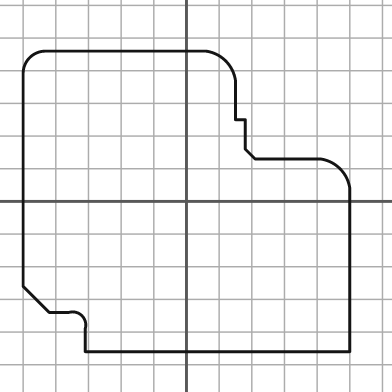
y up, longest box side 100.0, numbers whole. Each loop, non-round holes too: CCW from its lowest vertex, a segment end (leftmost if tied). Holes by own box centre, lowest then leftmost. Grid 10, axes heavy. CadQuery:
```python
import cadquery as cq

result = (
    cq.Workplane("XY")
    .moveTo(-31.0, -46.0)
    .lineTo(50.0, -46.0)
    .lineTo(50.0, 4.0)
    .threePointArc((47.0, 10.0), (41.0, 13.0))
    .lineTo(21.0, 13.0)
    .lineTo(18.0, 16.0)
    .lineTo(18.0, 25.0)
    .lineTo(15.0, 25.0)
    .lineTo(15.0, 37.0)
    .threePointArc((12.0, 43.0), (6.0, 46.0))
    .lineTo(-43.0, 46.0)
    .threePointArc((-48.0, 44.0), (-50.0, 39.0))
    .lineTo(-50.0, -26.0)
    .lineTo(-42.0, -34.0)
    .lineTo(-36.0, -34.0)
    .threePointArc((-32.0, -35.0), (-31.0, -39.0))
    .close()
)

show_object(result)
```